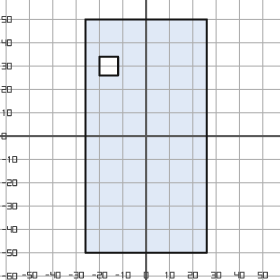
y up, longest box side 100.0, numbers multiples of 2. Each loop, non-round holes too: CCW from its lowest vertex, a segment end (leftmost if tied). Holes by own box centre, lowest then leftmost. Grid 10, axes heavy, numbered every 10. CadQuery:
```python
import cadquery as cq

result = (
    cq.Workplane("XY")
    .moveTo(-26.0, -50.0)
    .lineTo(26.0, -50.0)
    .lineTo(26.0, 50.0)
    .lineTo(-26.0, 50.0)
    .close()
    .moveTo(-20.0, 26.0)
    .lineTo(-12.0, 26.0)
    .lineTo(-12.0, 34.0)
    .lineTo(-20.0, 34.0)
    .close()
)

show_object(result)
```